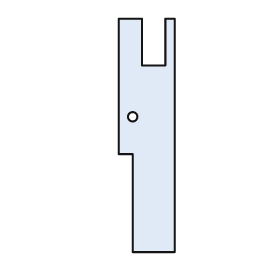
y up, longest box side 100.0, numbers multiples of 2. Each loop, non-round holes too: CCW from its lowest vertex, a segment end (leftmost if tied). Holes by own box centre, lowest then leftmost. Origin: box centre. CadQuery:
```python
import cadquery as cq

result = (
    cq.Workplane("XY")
    .moveTo(-6.0, -50.0)
    .lineTo(12.0, -50.0)
    .lineTo(12.0, 50.0)
    .lineTo(8.0, 50.0)
    .lineTo(8.0, 30.0)
    .lineTo(-2.0, 30.0)
    .lineTo(-2.0, 50.0)
    .lineTo(-12.0, 50.0)
    .lineTo(-12.0, -8.0)
    .lineTo(-6.0, -8.0)
    .close()
    .moveTo(-6.0, 8.0)
    .circle(2.0)
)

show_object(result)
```